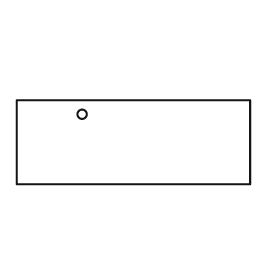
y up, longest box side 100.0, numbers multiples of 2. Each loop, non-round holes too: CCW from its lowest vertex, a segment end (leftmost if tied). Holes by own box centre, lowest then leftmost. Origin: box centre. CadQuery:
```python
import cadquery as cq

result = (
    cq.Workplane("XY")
    .moveTo(-50.0, -18.0)
    .lineTo(50.0, -18.0)
    .lineTo(50.0, 18.0)
    .lineTo(-50.0, 18.0)
    .close()
    .moveTo(-22.0, 12.0)
    .circle(2.0)
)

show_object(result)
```